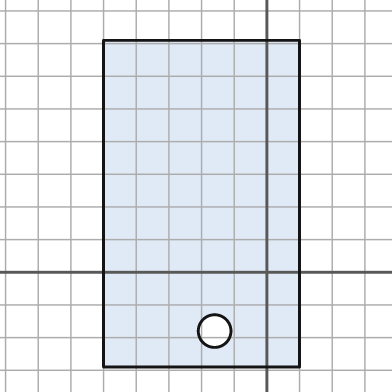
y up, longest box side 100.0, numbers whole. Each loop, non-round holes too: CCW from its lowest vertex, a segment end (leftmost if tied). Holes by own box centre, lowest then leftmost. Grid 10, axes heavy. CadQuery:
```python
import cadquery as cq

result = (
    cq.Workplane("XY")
    .moveTo(-50.0, -29.0)
    .lineTo(10.0, -29.0)
    .lineTo(10.0, 71.0)
    .lineTo(-50.0, 71.0)
    .close()
    .moveTo(-16.0, -18.0)
    .circle(5.0)
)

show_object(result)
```